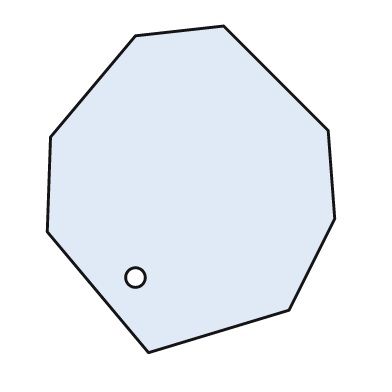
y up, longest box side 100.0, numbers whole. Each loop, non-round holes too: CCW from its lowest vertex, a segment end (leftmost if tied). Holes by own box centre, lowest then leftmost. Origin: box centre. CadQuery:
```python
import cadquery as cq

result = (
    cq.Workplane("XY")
    .moveTo(-13.0, -50.0)
    .lineTo(30.0, -37.0)
    .lineTo(44.0, -9.0)
    .lineTo(42.0, 18.0)
    .lineTo(10.0, 50.0)
    .lineTo(-17.0, 47.0)
    .lineTo(-43.0, 16.0)
    .lineTo(-44.0, -13.0)
    .close()
    .moveTo(-17.0, -27.0)
    .circle(3.0)
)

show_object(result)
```